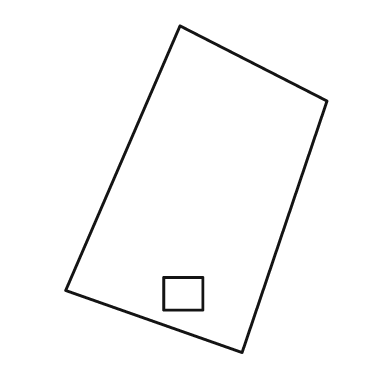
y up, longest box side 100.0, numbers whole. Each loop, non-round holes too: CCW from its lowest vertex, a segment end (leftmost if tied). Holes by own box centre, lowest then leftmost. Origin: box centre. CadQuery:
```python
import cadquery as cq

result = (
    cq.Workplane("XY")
    .moveTo(14.0, -50.0)
    .lineTo(40.0, 27.0)
    .lineTo(-5.0, 50.0)
    .lineTo(-40.0, -31.0)
    .close()
    .moveTo(-10.0, -37.0)
    .lineTo(2.0, -37.0)
    .lineTo(2.0, -27.0)
    .lineTo(-10.0, -27.0)
    .close()
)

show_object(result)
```